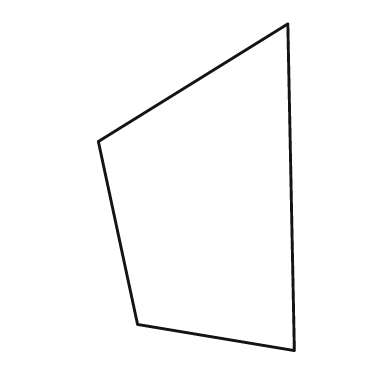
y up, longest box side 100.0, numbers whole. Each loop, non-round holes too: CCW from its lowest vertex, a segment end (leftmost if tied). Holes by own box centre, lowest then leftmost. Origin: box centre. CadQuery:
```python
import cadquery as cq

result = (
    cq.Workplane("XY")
    .moveTo(30.0, -50.0)
    .lineTo(28.0, 50.0)
    .lineTo(-30.0, 14.0)
    .lineTo(-18.0, -42.0)
    .close()
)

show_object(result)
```